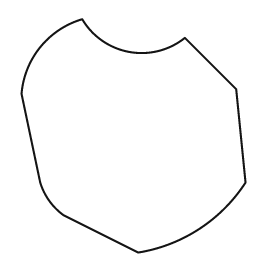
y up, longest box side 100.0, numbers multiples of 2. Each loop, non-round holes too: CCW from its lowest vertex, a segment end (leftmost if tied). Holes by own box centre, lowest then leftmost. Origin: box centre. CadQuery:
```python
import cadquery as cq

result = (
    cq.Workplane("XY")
    .moveTo(2.0, -50.0)
    .threePointArc((28.0, -40.0), (48.0, -20.0))
    .lineTo(44.0, 20.0)
    .lineTo(22.0, 42.0)
    .threePointArc((-2.0, 36.0), (-22.0, 50.0))
    .threePointArc((-40.0, 38.0), (-48.0, 18.0))
    .lineTo(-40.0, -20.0)
    .threePointArc((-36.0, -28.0), (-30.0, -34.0))
    .close()
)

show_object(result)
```